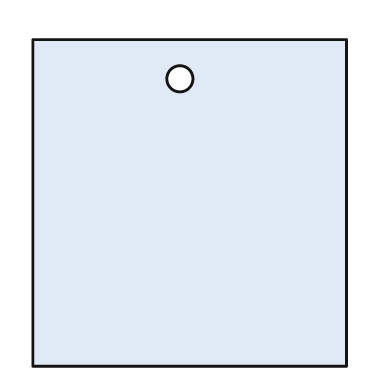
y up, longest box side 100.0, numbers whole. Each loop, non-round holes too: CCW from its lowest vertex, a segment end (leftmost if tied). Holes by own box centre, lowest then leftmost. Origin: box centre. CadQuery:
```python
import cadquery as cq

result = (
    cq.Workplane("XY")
    .moveTo(-48.0, -50.0)
    .lineTo(48.0, -50.0)
    .lineTo(48.0, 50.0)
    .lineTo(-48.0, 50.0)
    .close()
    .moveTo(-3.0, 38.0)
    .circle(4.0)
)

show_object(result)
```